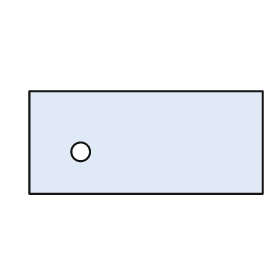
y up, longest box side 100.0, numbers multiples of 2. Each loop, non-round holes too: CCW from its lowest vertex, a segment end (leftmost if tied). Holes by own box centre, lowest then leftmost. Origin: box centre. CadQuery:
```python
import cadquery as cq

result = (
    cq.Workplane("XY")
    .moveTo(-50.0, -22.0)
    .lineTo(50.0, -22.0)
    .lineTo(50.0, 22.0)
    .lineTo(-50.0, 22.0)
    .close()
    .moveTo(-28.0, -4.0)
    .circle(4.0)
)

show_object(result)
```